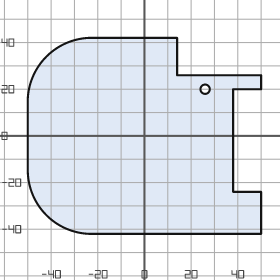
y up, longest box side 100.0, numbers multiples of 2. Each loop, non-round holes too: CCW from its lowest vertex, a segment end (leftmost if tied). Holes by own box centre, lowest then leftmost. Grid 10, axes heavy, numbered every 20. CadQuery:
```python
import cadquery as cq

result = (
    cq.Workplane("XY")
    .moveTo(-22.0, -42.0)
    .lineTo(50.0, -42.0)
    .lineTo(50.0, -24.0)
    .lineTo(38.0, -24.0)
    .lineTo(38.0, 20.0)
    .lineTo(50.0, 20.0)
    .lineTo(50.0, 26.0)
    .lineTo(14.0, 26.0)
    .lineTo(14.0, 42.0)
    .lineTo(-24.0, 42.0)
    .threePointArc((-42.0, 34.0), (-50.0, 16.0))
    .lineTo(-50.0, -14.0)
    .threePointArc((-42.0, -34.0), (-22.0, -42.0))
    .close()
    .moveTo(26.0, 20.0)
    .circle(2.0)
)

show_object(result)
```